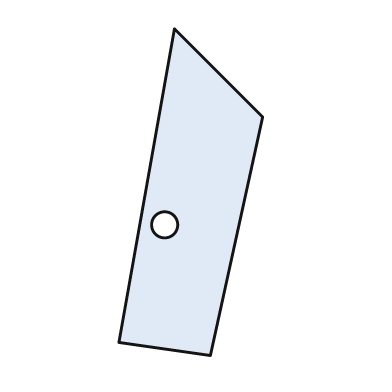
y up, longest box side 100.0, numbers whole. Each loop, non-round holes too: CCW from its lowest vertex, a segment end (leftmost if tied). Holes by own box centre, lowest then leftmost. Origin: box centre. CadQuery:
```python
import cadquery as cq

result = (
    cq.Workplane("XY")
    .moveTo(6.0, -50.0)
    .lineTo(22.0, 23.0)
    .lineTo(-5.0, 50.0)
    .lineTo(-22.0, -46.0)
    .close()
    .moveTo(-8.0, -10.0)
    .circle(4.0)
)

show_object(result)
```